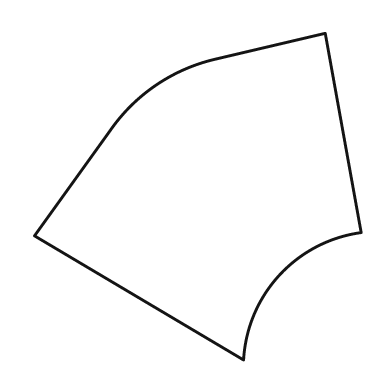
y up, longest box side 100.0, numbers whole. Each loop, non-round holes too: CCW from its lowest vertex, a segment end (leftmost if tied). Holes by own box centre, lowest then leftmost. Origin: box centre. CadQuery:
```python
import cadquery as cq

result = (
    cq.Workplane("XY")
    .moveTo(14.0, -50.0)
    .threePointArc((25.0, -24.0), (50.0, -11.0))
    .lineTo(39.0, 50.0)
    .lineTo(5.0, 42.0)
    .threePointArc((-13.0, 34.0), (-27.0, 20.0))
    .lineTo(-50.0, -12.0)
    .close()
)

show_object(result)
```